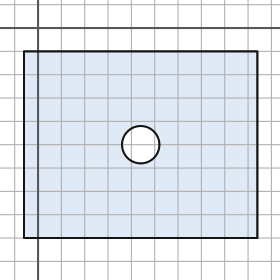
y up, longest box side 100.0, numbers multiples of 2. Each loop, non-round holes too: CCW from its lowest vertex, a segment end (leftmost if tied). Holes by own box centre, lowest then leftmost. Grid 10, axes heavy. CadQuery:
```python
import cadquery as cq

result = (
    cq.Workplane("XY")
    .moveTo(-6.0, -90.0)
    .lineTo(94.0, -90.0)
    .lineTo(94.0, -10.0)
    .lineTo(-6.0, -10.0)
    .close()
    .moveTo(44.0, -50.0)
    .circle(8.0)
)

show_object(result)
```